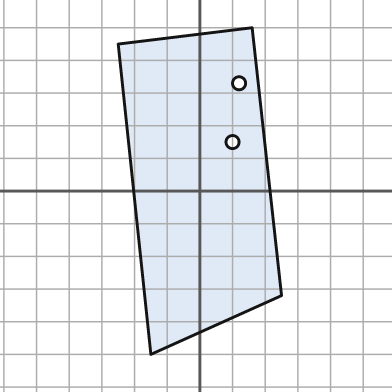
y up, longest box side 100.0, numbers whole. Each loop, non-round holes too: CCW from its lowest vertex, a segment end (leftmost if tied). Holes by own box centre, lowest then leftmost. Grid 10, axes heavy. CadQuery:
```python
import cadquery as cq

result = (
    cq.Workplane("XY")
    .moveTo(-15.0, -50.0)
    .lineTo(25.0, -32.0)
    .lineTo(16.0, 50.0)
    .lineTo(-25.0, 45.0)
    .close()
    .moveTo(10.0, 15.0)
    .circle(2.0)
    .moveTo(12.0, 33.0)
    .circle(2.0)
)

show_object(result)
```